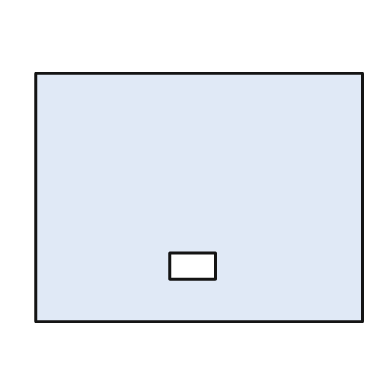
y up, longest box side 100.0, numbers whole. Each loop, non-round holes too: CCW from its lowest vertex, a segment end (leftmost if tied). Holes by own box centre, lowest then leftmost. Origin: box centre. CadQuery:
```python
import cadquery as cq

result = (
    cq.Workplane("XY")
    .moveTo(-50.0, -38.0)
    .lineTo(50.0, -38.0)
    .lineTo(50.0, 38.0)
    .lineTo(-50.0, 38.0)
    .close()
    .moveTo(-9.0, -25.0)
    .lineTo(5.0, -25.0)
    .lineTo(5.0, -17.0)
    .lineTo(-9.0, -17.0)
    .close()
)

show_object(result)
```